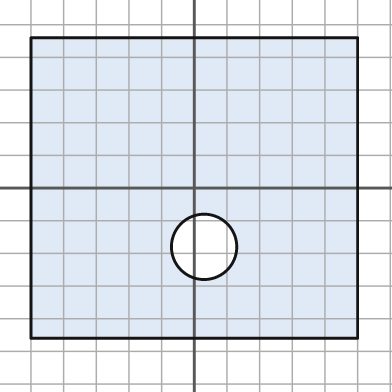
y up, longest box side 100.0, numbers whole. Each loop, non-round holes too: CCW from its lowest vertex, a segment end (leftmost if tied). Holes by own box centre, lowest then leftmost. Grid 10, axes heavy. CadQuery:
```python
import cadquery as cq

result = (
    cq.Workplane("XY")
    .moveTo(-50.0, -46.0)
    .lineTo(50.0, -46.0)
    .lineTo(50.0, 46.0)
    .lineTo(-50.0, 46.0)
    .close()
    .moveTo(3.0, -18.0)
    .circle(10.0)
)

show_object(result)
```